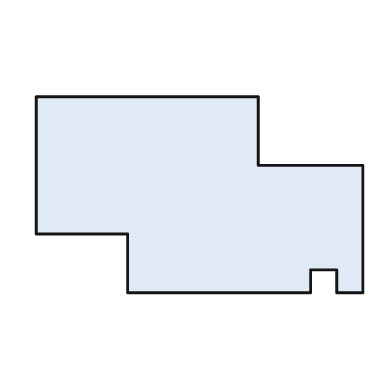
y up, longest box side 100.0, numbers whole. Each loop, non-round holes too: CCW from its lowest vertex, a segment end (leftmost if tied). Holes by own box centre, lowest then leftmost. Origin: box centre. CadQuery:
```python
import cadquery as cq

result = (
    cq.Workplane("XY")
    .moveTo(-22.0, -30.0)
    .lineTo(34.0, -30.0)
    .lineTo(34.0, -23.0)
    .lineTo(42.0, -23.0)
    .lineTo(42.0, -30.0)
    .lineTo(50.0, -30.0)
    .lineTo(50.0, 9.0)
    .lineTo(18.0, 9.0)
    .lineTo(18.0, 30.0)
    .lineTo(-50.0, 30.0)
    .lineTo(-50.0, -12.0)
    .lineTo(-22.0, -12.0)
    .close()
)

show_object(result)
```